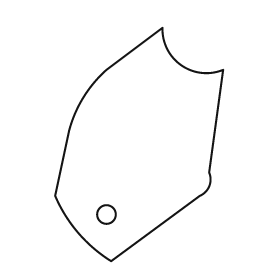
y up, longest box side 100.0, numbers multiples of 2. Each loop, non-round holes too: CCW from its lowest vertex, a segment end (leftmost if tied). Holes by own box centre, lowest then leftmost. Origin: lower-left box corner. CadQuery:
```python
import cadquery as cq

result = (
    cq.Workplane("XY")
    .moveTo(24.0, 0.0)
    .lineTo(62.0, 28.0)
    .threePointArc((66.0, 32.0), (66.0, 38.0))
    .lineTo(72.0, 82.0)
    .threePointArc((54.0, 84.0), (46.0, 100.0))
    .lineTo(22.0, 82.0)
    .threePointArc((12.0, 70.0), (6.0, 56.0))
    .lineTo(0.0, 28.0)
    .threePointArc((10.0, 12.0), (24.0, 0.0))
    .close()
    .moveTo(22.0, 20.0)
    .circle(4.0)
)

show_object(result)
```